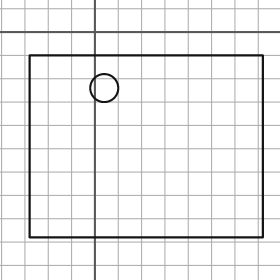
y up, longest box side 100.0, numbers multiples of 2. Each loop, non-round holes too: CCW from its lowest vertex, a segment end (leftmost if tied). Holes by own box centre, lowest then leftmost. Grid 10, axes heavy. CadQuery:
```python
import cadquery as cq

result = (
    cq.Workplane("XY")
    .moveTo(-28.0, -88.0)
    .lineTo(72.0, -88.0)
    .lineTo(72.0, -10.0)
    .lineTo(-28.0, -10.0)
    .close()
    .moveTo(4.0, -24.0)
    .circle(6.0)
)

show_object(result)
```